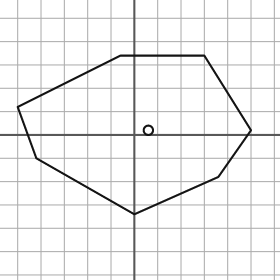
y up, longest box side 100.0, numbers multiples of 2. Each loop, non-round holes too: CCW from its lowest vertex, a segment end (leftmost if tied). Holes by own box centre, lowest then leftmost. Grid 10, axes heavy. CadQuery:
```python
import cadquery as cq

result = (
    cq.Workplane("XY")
    .moveTo(0.0, -34.0)
    .lineTo(36.0, -18.0)
    .lineTo(50.0, 2.0)
    .lineTo(30.0, 34.0)
    .lineTo(-6.0, 34.0)
    .lineTo(-50.0, 12.0)
    .lineTo(-42.0, -10.0)
    .close()
    .moveTo(6.0, 2.0)
    .circle(2.0)
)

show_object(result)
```